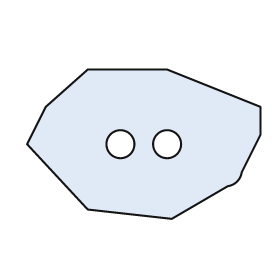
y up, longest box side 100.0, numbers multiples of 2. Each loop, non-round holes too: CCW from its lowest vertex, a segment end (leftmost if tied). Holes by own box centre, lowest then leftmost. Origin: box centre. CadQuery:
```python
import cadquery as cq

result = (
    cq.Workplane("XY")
    .moveTo(12.0, -32.0)
    .lineTo(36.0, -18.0)
    .threePointArc((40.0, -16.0), (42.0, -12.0))
    .lineTo(50.0, 4.0)
    .lineTo(50.0, 16.0)
    .lineTo(10.0, 32.0)
    .lineTo(-24.0, 32.0)
    .lineTo(-42.0, 16.0)
    .lineTo(-50.0, 0.0)
    .lineTo(-24.0, -28.0)
    .close()
    .moveTo(-10.0, 0.0)
    .circle(6.0)
    .moveTo(10.0, 0.0)
    .circle(6.0)
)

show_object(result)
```